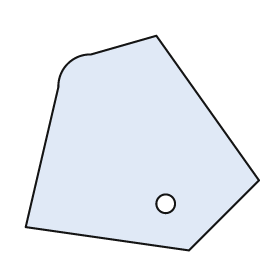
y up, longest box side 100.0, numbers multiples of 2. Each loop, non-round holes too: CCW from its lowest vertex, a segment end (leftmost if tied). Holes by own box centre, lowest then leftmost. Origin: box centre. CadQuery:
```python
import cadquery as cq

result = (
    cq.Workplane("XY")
    .moveTo(20.0, -46.0)
    .lineTo(50.0, -16.0)
    .lineTo(6.0, 46.0)
    .lineTo(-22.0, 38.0)
    .threePointArc((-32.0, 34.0), (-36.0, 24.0))
    .lineTo(-50.0, -36.0)
    .close()
    .moveTo(10.0, -26.0)
    .circle(4.0)
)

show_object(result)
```